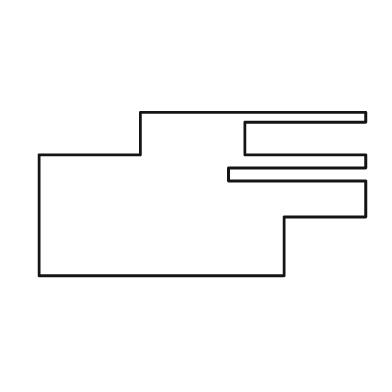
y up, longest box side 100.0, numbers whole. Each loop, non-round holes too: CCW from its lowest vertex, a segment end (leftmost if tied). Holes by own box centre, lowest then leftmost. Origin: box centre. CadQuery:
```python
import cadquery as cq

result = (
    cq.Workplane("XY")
    .moveTo(-50.0, -25.0)
    .lineTo(25.0, -25.0)
    .lineTo(25.0, -7.0)
    .lineTo(50.0, -7.0)
    .lineTo(50.0, 4.0)
    .lineTo(8.0, 4.0)
    .lineTo(8.0, 8.0)
    .lineTo(50.0, 8.0)
    .lineTo(50.0, 12.0)
    .lineTo(13.0, 12.0)
    .lineTo(13.0, 22.0)
    .lineTo(50.0, 22.0)
    .lineTo(50.0, 25.0)
    .lineTo(-19.0, 25.0)
    .lineTo(-19.0, 12.0)
    .lineTo(-50.0, 12.0)
    .close()
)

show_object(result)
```